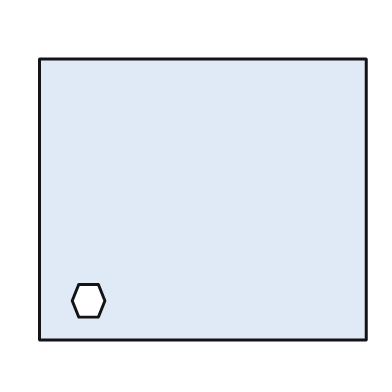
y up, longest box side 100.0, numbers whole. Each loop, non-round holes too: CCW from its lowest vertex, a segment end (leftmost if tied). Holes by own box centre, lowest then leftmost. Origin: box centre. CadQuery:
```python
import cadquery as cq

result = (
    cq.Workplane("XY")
    .moveTo(-50.0, -43.0)
    .lineTo(50.0, -43.0)
    .lineTo(50.0, 43.0)
    .lineTo(-50.0, 43.0)
    .close()
    .moveTo(-38.0, -36.0)
    .lineTo(-32.0, -36.0)
    .lineTo(-30.0, -31.0)
    .lineTo(-32.0, -26.0)
    .lineTo(-38.0, -26.0)
    .lineTo(-40.0, -31.0)
    .close()
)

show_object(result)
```